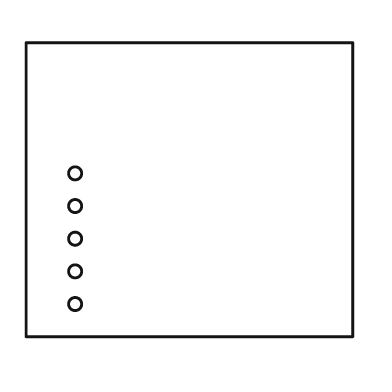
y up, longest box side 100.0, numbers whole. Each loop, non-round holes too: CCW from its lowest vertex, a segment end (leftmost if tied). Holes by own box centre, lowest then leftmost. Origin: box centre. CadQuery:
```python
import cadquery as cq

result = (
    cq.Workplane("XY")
    .moveTo(-50.0, -45.0)
    .lineTo(50.0, -45.0)
    .lineTo(50.0, 45.0)
    .lineTo(-50.0, 45.0)
    .close()
    .moveTo(-35.0, -35.0)
    .circle(2.0)
    .moveTo(-35.0, -25.0)
    .circle(2.0)
    .moveTo(-35.0, -15.0)
    .circle(2.0)
    .moveTo(-35.0, -5.0)
    .circle(2.0)
    .moveTo(-35.0, 5.0)
    .circle(2.0)
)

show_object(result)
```